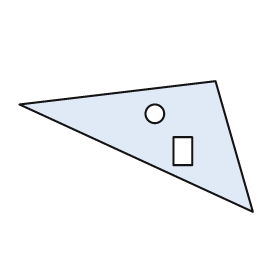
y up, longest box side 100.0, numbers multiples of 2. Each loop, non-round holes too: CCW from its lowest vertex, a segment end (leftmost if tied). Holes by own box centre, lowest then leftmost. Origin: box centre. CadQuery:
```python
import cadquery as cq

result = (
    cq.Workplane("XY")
    .moveTo(50.0, -28.0)
    .lineTo(34.0, 28.0)
    .lineTo(-50.0, 18.0)
    .close()
    .moveTo(16.0, -8.0)
    .lineTo(24.0, -8.0)
    .lineTo(24.0, 4.0)
    .lineTo(16.0, 4.0)
    .close()
    .moveTo(8.0, 14.0)
    .circle(4.0)
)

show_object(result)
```